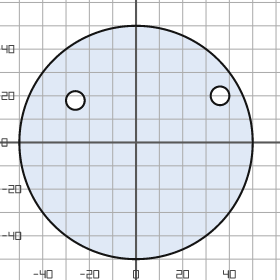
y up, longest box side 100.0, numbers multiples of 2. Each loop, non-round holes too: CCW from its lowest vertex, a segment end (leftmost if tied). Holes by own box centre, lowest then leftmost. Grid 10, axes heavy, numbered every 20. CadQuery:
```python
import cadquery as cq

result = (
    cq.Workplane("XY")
    .moveTo(0.0, 0.0)
    .circle(50.0)
    .moveTo(-26.0, 18.0)
    .circle(4.0)
    .moveTo(36.0, 20.0)
    .circle(4.0)
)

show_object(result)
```